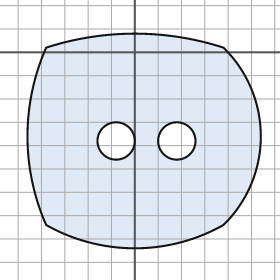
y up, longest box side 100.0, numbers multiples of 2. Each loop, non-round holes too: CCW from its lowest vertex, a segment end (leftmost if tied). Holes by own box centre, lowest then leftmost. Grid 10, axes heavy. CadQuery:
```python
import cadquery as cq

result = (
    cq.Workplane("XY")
    .moveTo(-38.0, -74.0)
    .threePointArc((0.0, -84.0), (38.0, -74.0))
    .threePointArc((54.0, -36.0), (38.0, 2.0))
    .threePointArc((0.0, 8.0), (-38.0, 2.0))
    .threePointArc((-46.0, -36.0), (-38.0, -74.0))
    .close()
    .moveTo(-8.0, -38.0)
    .circle(8.0)
    .moveTo(18.0, -38.0)
    .circle(8.0)
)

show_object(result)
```